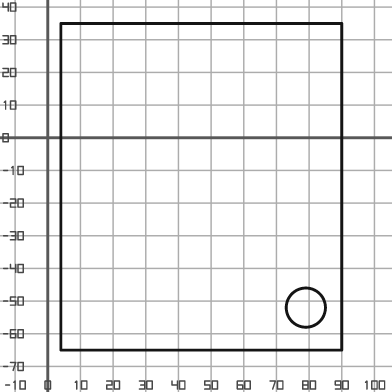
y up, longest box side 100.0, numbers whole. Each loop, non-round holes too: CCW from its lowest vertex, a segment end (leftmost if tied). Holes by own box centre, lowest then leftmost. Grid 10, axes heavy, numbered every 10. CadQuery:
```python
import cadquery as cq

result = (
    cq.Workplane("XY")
    .moveTo(4.0, -65.0)
    .lineTo(90.0, -65.0)
    .lineTo(90.0, 35.0)
    .lineTo(4.0, 35.0)
    .close()
    .moveTo(79.0, -52.0)
    .circle(6.0)
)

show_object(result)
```